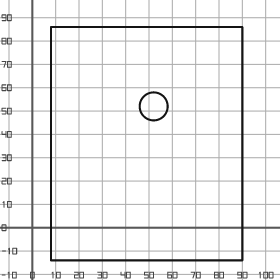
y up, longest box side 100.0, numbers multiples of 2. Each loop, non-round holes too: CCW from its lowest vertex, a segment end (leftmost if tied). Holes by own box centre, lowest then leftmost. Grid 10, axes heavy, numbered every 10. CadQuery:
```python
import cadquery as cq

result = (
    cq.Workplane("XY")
    .moveTo(8.0, -14.0)
    .lineTo(90.0, -14.0)
    .lineTo(90.0, 86.0)
    .lineTo(8.0, 86.0)
    .close()
    .moveTo(52.0, 52.0)
    .circle(6.0)
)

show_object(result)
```